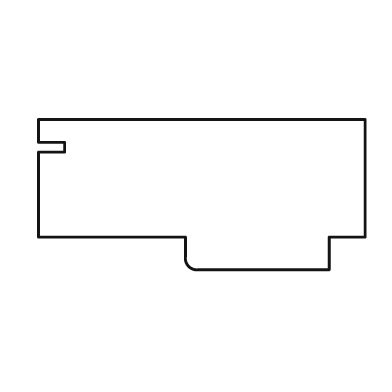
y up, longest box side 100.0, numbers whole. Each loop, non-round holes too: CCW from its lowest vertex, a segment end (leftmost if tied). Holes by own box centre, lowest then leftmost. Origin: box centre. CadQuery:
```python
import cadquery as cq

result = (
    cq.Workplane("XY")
    .moveTo(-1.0, -23.0)
    .lineTo(39.0, -23.0)
    .lineTo(39.0, -13.0)
    .lineTo(50.0, -13.0)
    .lineTo(50.0, 23.0)
    .lineTo(-50.0, 23.0)
    .lineTo(-50.0, 16.0)
    .lineTo(-42.0, 16.0)
    .lineTo(-42.0, 13.0)
    .lineTo(-50.0, 13.0)
    .lineTo(-50.0, -13.0)
    .lineTo(-5.0, -13.0)
    .lineTo(-5.0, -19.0)
    .threePointArc((-4.0, -22.0), (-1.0, -23.0))
    .close()
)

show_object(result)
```